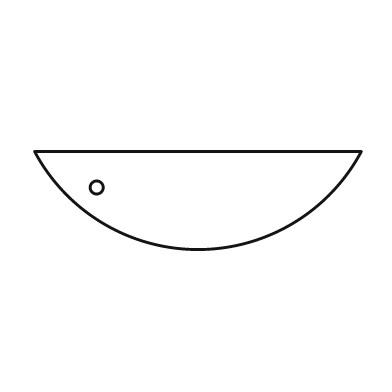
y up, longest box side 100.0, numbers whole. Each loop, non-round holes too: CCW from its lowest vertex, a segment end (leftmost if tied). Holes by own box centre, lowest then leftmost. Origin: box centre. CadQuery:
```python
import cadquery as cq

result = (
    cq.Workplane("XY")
    .moveTo(-50.0, 15.0)
    .threePointArc((0.0, -15.0), (50.0, 15.0))
    .close()
    .moveTo(-31.0, 4.0)
    .circle(2.0)
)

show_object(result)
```